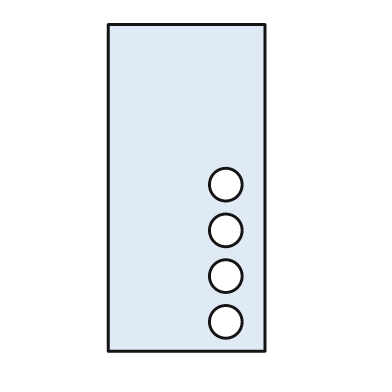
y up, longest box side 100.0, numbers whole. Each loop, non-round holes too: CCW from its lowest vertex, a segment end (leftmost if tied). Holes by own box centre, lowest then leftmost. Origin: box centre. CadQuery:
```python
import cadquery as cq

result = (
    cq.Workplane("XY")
    .moveTo(-24.0, -50.0)
    .lineTo(24.0, -50.0)
    .lineTo(24.0, 50.0)
    .lineTo(-24.0, 50.0)
    .close()
    .moveTo(12.0, -41.0)
    .circle(5.0)
    .moveTo(12.0, -27.0)
    .circle(5.0)
    .moveTo(12.0, -13.0)
    .circle(5.0)
    .moveTo(12.0, 1.0)
    .circle(5.0)
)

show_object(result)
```